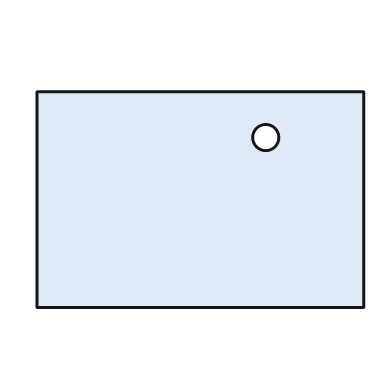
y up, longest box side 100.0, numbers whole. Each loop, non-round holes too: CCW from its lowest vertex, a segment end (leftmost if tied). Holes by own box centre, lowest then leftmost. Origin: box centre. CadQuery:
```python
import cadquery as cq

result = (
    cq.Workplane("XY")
    .moveTo(-50.0, -33.0)
    .lineTo(50.0, -33.0)
    .lineTo(50.0, 33.0)
    .lineTo(-50.0, 33.0)
    .close()
    .moveTo(20.0, 19.0)
    .circle(4.0)
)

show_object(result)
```